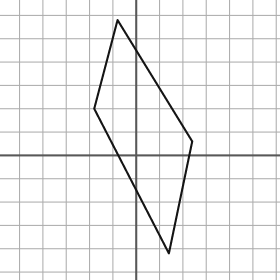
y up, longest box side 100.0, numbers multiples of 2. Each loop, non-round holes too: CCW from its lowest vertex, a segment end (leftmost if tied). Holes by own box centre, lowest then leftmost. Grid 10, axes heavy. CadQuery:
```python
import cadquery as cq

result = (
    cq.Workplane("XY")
    .moveTo(14.0, -42.0)
    .lineTo(24.0, 6.0)
    .lineTo(-8.0, 58.0)
    .lineTo(-18.0, 20.0)
    .close()
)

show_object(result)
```